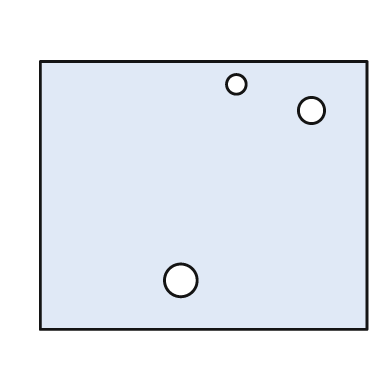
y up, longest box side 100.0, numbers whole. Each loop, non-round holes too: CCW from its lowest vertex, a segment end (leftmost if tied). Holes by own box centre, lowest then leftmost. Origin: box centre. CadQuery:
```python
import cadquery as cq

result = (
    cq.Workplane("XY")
    .moveTo(-50.0, -41.0)
    .lineTo(50.0, -41.0)
    .lineTo(50.0, 41.0)
    .lineTo(-50.0, 41.0)
    .close()
    .moveTo(-7.0, -26.0)
    .circle(5.0)
    .moveTo(33.0, 26.0)
    .circle(4.0)
    .moveTo(10.0, 34.0)
    .circle(3.0)
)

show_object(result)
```